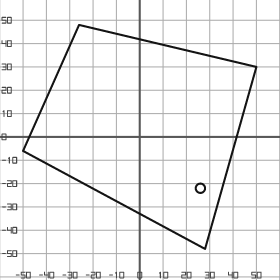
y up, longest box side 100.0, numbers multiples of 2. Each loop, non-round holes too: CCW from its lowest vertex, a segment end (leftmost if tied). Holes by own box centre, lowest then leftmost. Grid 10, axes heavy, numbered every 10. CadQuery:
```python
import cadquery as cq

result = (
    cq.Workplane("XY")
    .moveTo(28.0, -48.0)
    .lineTo(50.0, 30.0)
    .lineTo(-26.0, 48.0)
    .lineTo(-50.0, -6.0)
    .close()
    .moveTo(26.0, -22.0)
    .circle(2.0)
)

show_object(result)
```